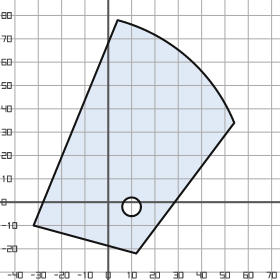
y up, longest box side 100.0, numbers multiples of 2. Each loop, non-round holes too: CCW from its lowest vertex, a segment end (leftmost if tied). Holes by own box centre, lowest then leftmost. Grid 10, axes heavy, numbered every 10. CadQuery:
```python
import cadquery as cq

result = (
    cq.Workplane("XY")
    .moveTo(12.0, -22.0)
    .lineTo(54.0, 34.0)
    .threePointArc((34.0, 62.0), (4.0, 78.0))
    .lineTo(-32.0, -10.0)
    .close()
    .moveTo(10.0, -2.0)
    .circle(4.0)
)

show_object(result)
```